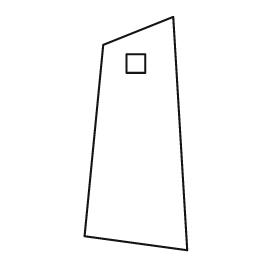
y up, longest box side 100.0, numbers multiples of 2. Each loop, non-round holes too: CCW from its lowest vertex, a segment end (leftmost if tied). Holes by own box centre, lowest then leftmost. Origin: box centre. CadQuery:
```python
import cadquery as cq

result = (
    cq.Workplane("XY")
    .moveTo(22.0, -50.0)
    .lineTo(16.0, 50.0)
    .lineTo(-14.0, 38.0)
    .lineTo(-22.0, -44.0)
    .close()
    .moveTo(-4.0, 26.0)
    .lineTo(4.0, 26.0)
    .lineTo(4.0, 34.0)
    .lineTo(-4.0, 34.0)
    .close()
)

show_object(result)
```